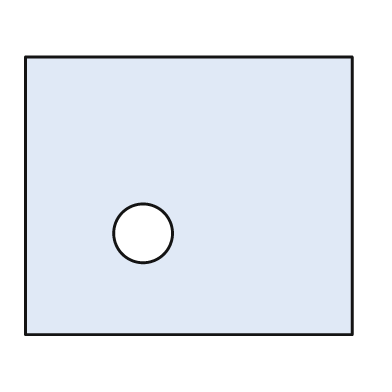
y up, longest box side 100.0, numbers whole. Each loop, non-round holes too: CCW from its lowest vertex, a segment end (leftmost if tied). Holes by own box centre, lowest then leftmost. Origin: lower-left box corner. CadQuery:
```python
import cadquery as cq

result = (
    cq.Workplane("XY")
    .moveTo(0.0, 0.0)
    .lineTo(100.0, 0.0)
    .lineTo(100.0, 85.0)
    .lineTo(0.0, 85.0)
    .close()
    .moveTo(36.0, 31.0)
    .circle(9.0)
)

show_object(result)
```